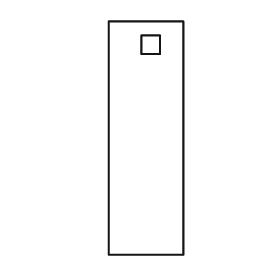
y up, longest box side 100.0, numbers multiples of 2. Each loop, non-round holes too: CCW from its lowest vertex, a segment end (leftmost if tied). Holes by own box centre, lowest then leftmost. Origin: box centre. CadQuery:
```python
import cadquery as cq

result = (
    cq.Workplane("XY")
    .moveTo(-16.0, -50.0)
    .lineTo(16.0, -50.0)
    .lineTo(16.0, 50.0)
    .lineTo(-16.0, 50.0)
    .close()
    .moveTo(-2.0, 36.0)
    .lineTo(6.0, 36.0)
    .lineTo(6.0, 44.0)
    .lineTo(-2.0, 44.0)
    .close()
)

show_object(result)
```